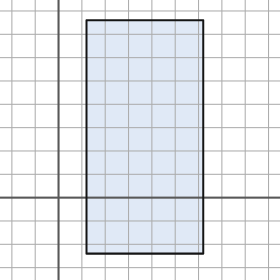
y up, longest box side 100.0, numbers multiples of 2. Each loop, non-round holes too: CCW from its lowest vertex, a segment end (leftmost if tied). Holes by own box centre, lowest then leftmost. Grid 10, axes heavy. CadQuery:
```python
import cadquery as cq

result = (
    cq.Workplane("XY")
    .moveTo(12.0, -24.0)
    .lineTo(62.0, -24.0)
    .lineTo(62.0, 76.0)
    .lineTo(12.0, 76.0)
    .close()
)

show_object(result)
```